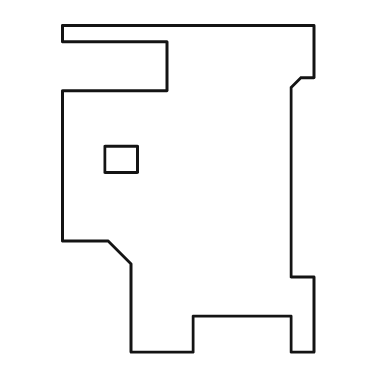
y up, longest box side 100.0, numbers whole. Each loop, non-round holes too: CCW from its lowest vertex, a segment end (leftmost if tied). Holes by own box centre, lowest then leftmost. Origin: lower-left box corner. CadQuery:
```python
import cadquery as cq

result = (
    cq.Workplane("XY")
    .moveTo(21.0, 0.0)
    .lineTo(40.0, 0.0)
    .lineTo(40.0, 11.0)
    .lineTo(70.0, 11.0)
    .lineTo(70.0, 0.0)
    .lineTo(77.0, 0.0)
    .lineTo(77.0, 23.0)
    .lineTo(70.0, 23.0)
    .lineTo(70.0, 81.0)
    .lineTo(73.0, 84.0)
    .lineTo(77.0, 84.0)
    .lineTo(77.0, 100.0)
    .lineTo(0.0, 100.0)
    .lineTo(0.0, 95.0)
    .lineTo(32.0, 95.0)
    .lineTo(32.0, 80.0)
    .lineTo(0.0, 80.0)
    .lineTo(0.0, 34.0)
    .lineTo(14.0, 34.0)
    .lineTo(21.0, 27.0)
    .close()
    .moveTo(13.0, 55.0)
    .lineTo(23.0, 55.0)
    .lineTo(23.0, 63.0)
    .lineTo(13.0, 63.0)
    .close()
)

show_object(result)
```